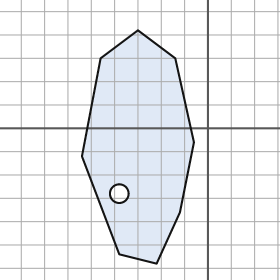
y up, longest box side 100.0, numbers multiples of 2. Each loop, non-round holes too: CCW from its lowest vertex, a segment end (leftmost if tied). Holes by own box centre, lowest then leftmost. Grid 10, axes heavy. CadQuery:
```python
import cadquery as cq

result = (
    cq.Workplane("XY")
    .moveTo(-22.0, -58.0)
    .lineTo(-12.0, -36.0)
    .lineTo(-6.0, -6.0)
    .lineTo(-14.0, 30.0)
    .lineTo(-30.0, 42.0)
    .lineTo(-46.0, 30.0)
    .lineTo(-54.0, -12.0)
    .lineTo(-38.0, -54.0)
    .close()
    .moveTo(-38.0, -28.0)
    .circle(4.0)
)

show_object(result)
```